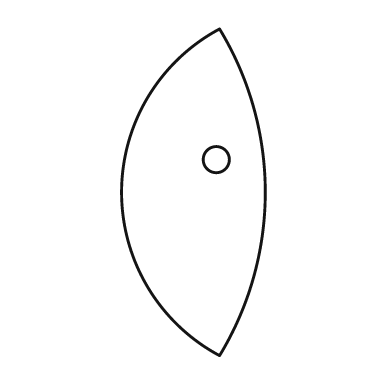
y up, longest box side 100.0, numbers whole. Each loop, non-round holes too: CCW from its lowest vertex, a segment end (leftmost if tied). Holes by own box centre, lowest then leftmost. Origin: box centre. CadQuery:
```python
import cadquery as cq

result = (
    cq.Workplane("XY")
    .moveTo(8.0, -50.0)
    .threePointArc((22.0, 0.0), (8.0, 50.0))
    .threePointArc((-22.0, 0.0), (8.0, -50.0))
    .close()
    .moveTo(7.0, 10.0)
    .circle(4.0)
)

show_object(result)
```